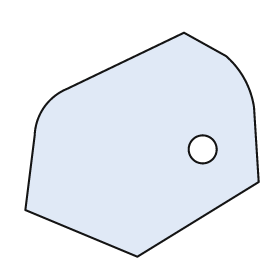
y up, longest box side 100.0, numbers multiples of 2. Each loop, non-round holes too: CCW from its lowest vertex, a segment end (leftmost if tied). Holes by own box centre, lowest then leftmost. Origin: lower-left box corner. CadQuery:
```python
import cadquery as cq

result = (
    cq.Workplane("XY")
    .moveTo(48.0, 0.0)
    .lineTo(100.0, 32.0)
    .lineTo(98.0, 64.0)
    .threePointArc((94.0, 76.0), (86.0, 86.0))
    .lineTo(68.0, 96.0)
    .lineTo(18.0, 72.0)
    .threePointArc((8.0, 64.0), (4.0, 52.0))
    .lineTo(0.0, 20.0)
    .close()
    .moveTo(76.0, 46.0)
    .circle(6.0)
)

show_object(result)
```